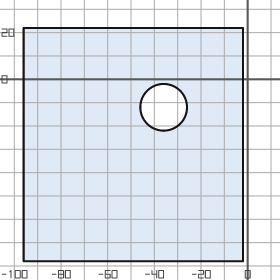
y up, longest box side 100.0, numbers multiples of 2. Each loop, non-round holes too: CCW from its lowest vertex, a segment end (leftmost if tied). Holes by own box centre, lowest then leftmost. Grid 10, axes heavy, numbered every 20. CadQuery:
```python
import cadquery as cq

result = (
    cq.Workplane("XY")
    .moveTo(-96.0, -78.0)
    .lineTo(-2.0, -78.0)
    .lineTo(-2.0, 22.0)
    .lineTo(-96.0, 22.0)
    .close()
    .moveTo(-36.0, -12.0)
    .circle(10.0)
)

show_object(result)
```